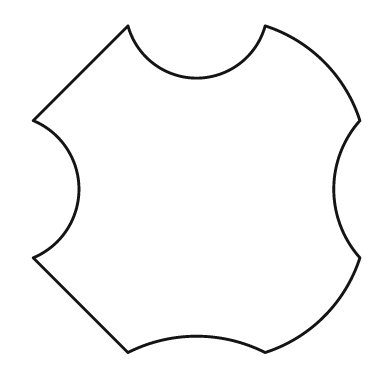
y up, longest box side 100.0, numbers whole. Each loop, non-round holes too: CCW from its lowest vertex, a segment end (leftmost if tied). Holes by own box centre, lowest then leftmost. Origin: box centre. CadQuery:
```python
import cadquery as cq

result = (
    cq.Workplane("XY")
    .moveTo(-21.0, -50.0)
    .threePointArc((0.0, -45.0), (21.0, -50.0))
    .threePointArc((39.0, -39.0), (50.0, -21.0))
    .threePointArc((42.0, 0.0), (50.0, 21.0))
    .threePointArc((39.0, 39.0), (21.0, 50.0))
    .threePointArc((0.0, 34.0), (-21.0, 50.0))
    .lineTo(-50.0, 21.0)
    .threePointArc((-36.0, 0.0), (-50.0, -21.0))
    .close()
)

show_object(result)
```